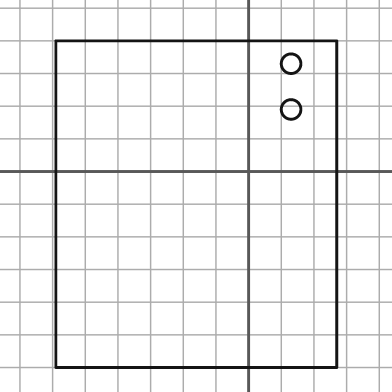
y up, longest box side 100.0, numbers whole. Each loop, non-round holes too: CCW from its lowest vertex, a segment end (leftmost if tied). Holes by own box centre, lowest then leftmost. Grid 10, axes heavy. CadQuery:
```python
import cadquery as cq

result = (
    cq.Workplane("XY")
    .moveTo(-59.0, -60.0)
    .lineTo(27.0, -60.0)
    .lineTo(27.0, 40.0)
    .lineTo(-59.0, 40.0)
    .close()
    .moveTo(13.0, 19.0)
    .circle(3.0)
    .moveTo(13.0, 33.0)
    .circle(3.0)
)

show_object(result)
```